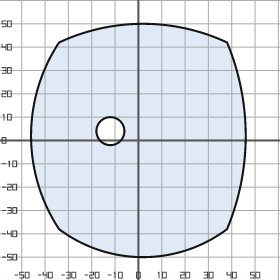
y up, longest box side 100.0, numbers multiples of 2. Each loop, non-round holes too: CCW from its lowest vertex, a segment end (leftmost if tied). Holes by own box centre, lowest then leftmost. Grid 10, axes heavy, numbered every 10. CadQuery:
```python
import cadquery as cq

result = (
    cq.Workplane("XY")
    .moveTo(-34.0, -38.0)
    .threePointArc((2.0, -50.0), (38.0, -38.0))
    .threePointArc((46.0, 2.0), (38.0, 42.0))
    .threePointArc((2.0, 50.0), (-34.0, 42.0))
    .threePointArc((-46.0, 2.0), (-34.0, -38.0))
    .close()
    .moveTo(-12.0, 4.0)
    .circle(6.0)
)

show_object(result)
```